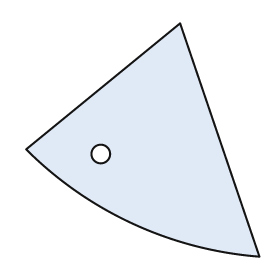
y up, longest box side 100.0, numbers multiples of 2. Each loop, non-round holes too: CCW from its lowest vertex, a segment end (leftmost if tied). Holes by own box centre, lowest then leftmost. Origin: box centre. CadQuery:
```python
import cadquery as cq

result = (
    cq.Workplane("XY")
    .moveTo(50.0, -50.0)
    .lineTo(16.0, 50.0)
    .lineTo(-50.0, -4.0)
    .threePointArc((-4.0, -36.0), (50.0, -50.0))
    .close()
    .moveTo(-18.0, -6.0)
    .circle(4.0)
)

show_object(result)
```